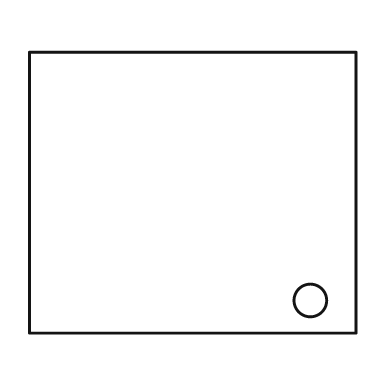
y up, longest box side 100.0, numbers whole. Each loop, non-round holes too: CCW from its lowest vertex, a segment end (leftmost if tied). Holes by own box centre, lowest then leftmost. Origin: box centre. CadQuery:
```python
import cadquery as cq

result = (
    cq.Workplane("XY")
    .moveTo(-50.0, -43.0)
    .lineTo(50.0, -43.0)
    .lineTo(50.0, 43.0)
    .lineTo(-50.0, 43.0)
    .close()
    .moveTo(36.0, -33.0)
    .circle(5.0)
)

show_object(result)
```